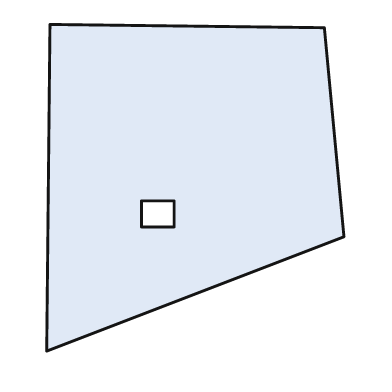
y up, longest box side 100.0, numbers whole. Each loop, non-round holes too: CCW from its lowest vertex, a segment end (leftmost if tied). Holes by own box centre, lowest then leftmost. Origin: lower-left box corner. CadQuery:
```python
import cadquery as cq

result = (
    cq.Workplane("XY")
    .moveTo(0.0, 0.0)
    .lineTo(91.0, 35.0)
    .lineTo(85.0, 99.0)
    .lineTo(1.0, 100.0)
    .close()
    .moveTo(29.0, 38.0)
    .lineTo(39.0, 38.0)
    .lineTo(39.0, 46.0)
    .lineTo(29.0, 46.0)
    .close()
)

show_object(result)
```